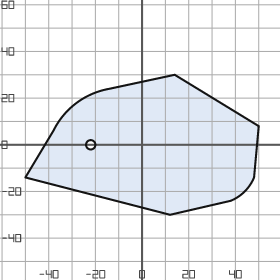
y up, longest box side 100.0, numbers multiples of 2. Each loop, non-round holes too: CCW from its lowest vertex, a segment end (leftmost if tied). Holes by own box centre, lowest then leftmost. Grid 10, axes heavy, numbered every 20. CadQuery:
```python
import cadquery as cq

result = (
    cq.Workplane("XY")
    .moveTo(12.0, -30.0)
    .lineTo(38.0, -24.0)
    .threePointArc((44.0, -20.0), (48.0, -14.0))
    .lineTo(50.0, 8.0)
    .lineTo(14.0, 30.0)
    .lineTo(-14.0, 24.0)
    .threePointArc((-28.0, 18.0), (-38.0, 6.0))
    .lineTo(-50.0, -14.0)
    .close()
    .moveTo(-22.0, 0.0)
    .circle(2.0)
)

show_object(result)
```